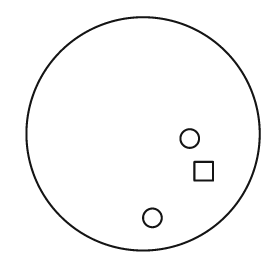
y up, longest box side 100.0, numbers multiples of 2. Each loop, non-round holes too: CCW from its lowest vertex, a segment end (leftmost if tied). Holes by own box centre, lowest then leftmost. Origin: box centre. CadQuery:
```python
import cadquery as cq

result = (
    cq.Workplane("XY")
    .moveTo(0.0, 0.0)
    .circle(50.0)
    .moveTo(4.0, -36.0)
    .circle(4.0)
    .moveTo(22.0, -20.0)
    .lineTo(30.0, -20.0)
    .lineTo(30.0, -12.0)
    .lineTo(22.0, -12.0)
    .close()
    .moveTo(20.0, -2.0)
    .circle(4.0)
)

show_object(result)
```